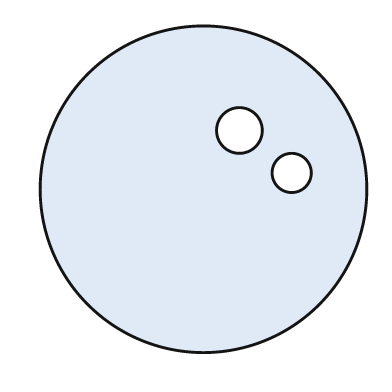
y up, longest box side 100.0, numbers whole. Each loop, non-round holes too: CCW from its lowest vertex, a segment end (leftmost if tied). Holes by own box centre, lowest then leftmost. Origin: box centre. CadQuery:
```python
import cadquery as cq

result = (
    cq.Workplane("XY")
    .moveTo(0.0, 0.0)
    .circle(50.0)
    .moveTo(27.0, 5.0)
    .circle(6.0)
    .moveTo(11.0, 18.0)
    .circle(7.0)
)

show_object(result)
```